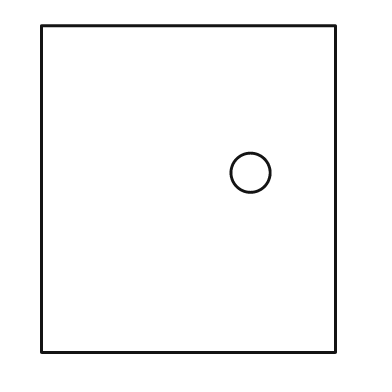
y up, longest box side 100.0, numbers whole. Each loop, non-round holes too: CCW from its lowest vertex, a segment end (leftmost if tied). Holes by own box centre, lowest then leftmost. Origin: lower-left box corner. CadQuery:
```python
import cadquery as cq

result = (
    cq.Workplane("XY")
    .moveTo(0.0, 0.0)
    .lineTo(90.0, 0.0)
    .lineTo(90.0, 100.0)
    .lineTo(0.0, 100.0)
    .close()
    .moveTo(64.0, 55.0)
    .circle(6.0)
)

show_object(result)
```